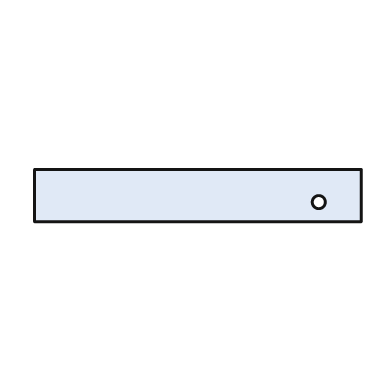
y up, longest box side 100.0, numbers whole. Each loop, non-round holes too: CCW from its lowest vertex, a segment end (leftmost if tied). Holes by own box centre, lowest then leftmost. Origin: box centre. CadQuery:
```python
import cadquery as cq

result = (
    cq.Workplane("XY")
    .moveTo(-50.0, -8.0)
    .lineTo(50.0, -8.0)
    .lineTo(50.0, 8.0)
    .lineTo(-50.0, 8.0)
    .close()
    .moveTo(37.0, -2.0)
    .circle(2.0)
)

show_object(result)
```